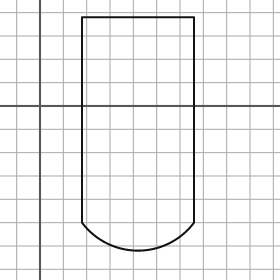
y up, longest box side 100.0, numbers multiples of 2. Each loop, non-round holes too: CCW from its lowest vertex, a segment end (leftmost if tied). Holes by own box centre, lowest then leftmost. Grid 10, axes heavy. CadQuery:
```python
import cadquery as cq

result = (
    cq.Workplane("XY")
    .moveTo(18.0, -50.0)
    .threePointArc((42.0, -62.0), (66.0, -50.0))
    .lineTo(66.0, 38.0)
    .lineTo(18.0, 38.0)
    .close()
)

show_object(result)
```